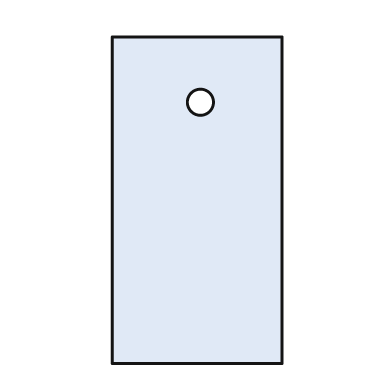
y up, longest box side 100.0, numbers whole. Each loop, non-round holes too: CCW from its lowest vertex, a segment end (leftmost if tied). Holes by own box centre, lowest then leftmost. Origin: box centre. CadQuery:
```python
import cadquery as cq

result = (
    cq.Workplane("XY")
    .moveTo(-26.0, -50.0)
    .lineTo(26.0, -50.0)
    .lineTo(26.0, 50.0)
    .lineTo(-26.0, 50.0)
    .close()
    .moveTo(1.0, 30.0)
    .circle(4.0)
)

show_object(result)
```